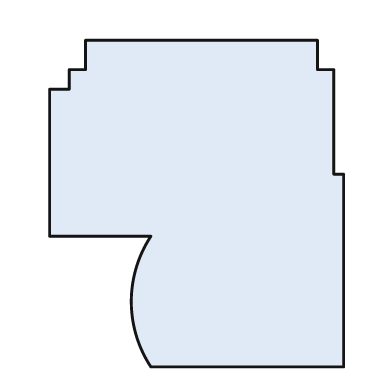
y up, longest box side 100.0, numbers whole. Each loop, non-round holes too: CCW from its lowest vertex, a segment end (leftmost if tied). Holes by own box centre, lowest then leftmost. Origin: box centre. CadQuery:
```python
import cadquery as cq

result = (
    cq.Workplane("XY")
    .moveTo(-14.0, -50.0)
    .lineTo(45.0, -50.0)
    .lineTo(45.0, 9.0)
    .lineTo(42.0, 9.0)
    .lineTo(42.0, 41.0)
    .lineTo(37.0, 41.0)
    .lineTo(37.0, 50.0)
    .lineTo(-34.0, 50.0)
    .lineTo(-34.0, 41.0)
    .lineTo(-39.0, 41.0)
    .lineTo(-39.0, 35.0)
    .lineTo(-45.0, 35.0)
    .lineTo(-45.0, -10.0)
    .lineTo(-14.0, -10.0)
    .threePointArc((-20.0, -30.0), (-14.0, -50.0))
    .close()
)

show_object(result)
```